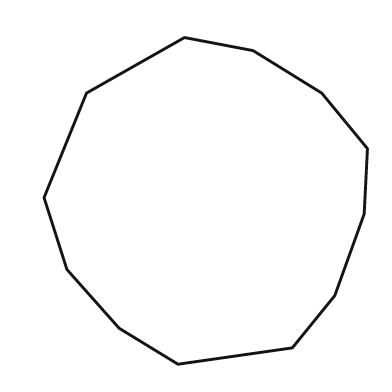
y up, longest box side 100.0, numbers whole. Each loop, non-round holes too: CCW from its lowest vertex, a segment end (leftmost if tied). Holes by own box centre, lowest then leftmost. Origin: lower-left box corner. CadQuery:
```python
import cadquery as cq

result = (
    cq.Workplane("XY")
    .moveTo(41.0, 0.0)
    .lineTo(76.0, 5.0)
    .lineTo(89.0, 21.0)
    .lineTo(98.0, 46.0)
    .lineTo(99.0, 66.0)
    .lineTo(85.0, 83.0)
    .lineTo(64.0, 96.0)
    .lineTo(43.0, 100.0)
    .lineTo(13.0, 83.0)
    .lineTo(0.0, 51.0)
    .lineTo(7.0, 29.0)
    .lineTo(23.0, 11.0)
    .close()
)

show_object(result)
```